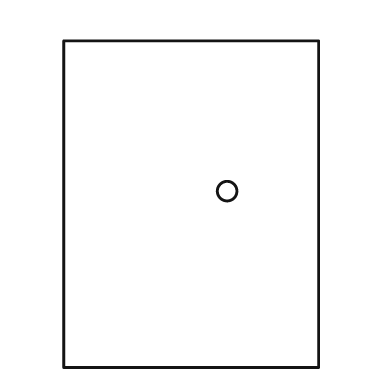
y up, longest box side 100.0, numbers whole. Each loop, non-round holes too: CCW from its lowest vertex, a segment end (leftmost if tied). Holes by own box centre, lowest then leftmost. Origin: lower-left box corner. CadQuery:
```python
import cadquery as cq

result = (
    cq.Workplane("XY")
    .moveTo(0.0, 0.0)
    .lineTo(78.0, 0.0)
    .lineTo(78.0, 100.0)
    .lineTo(0.0, 100.0)
    .close()
    .moveTo(50.0, 54.0)
    .circle(3.0)
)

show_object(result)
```